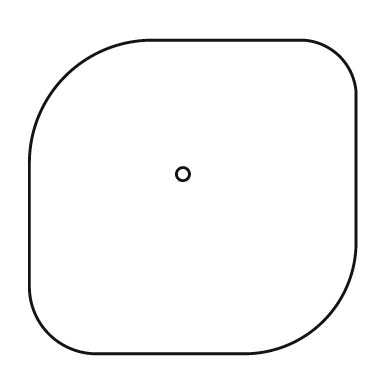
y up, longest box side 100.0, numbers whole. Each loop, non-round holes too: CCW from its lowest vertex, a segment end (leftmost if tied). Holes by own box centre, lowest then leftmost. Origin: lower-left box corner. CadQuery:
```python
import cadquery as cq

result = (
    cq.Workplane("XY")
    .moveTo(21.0, 0.0)
    .lineTo(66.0, 0.0)
    .threePointArc((90.0, 10.0), (100.0, 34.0))
    .lineTo(100.0, 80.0)
    .threePointArc((95.0, 91.0), (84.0, 96.0))
    .lineTo(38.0, 96.0)
    .threePointArc((11.0, 85.0), (0.0, 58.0))
    .lineTo(0.0, 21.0)
    .threePointArc((6.0, 6.0), (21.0, 0.0))
    .close()
    .moveTo(47.0, 55.0)
    .circle(2.0)
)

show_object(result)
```